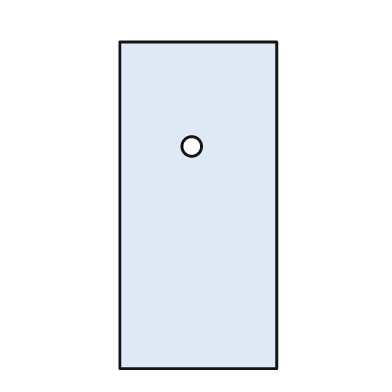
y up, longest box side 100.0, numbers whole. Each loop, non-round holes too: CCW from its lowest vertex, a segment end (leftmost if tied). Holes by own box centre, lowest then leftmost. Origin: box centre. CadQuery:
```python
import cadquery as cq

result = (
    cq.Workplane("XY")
    .moveTo(-24.0, -50.0)
    .lineTo(24.0, -50.0)
    .lineTo(24.0, 50.0)
    .lineTo(-24.0, 50.0)
    .close()
    .moveTo(-2.0, 18.0)
    .circle(3.0)
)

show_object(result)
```